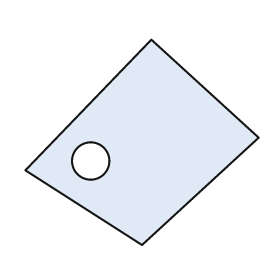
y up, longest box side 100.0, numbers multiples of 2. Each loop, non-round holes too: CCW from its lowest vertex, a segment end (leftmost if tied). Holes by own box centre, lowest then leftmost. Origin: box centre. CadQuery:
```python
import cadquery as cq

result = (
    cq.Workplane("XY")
    .moveTo(0.0, -44.0)
    .lineTo(50.0, 2.0)
    .lineTo(4.0, 44.0)
    .lineTo(-50.0, -12.0)
    .close()
    .moveTo(-22.0, -8.0)
    .circle(8.0)
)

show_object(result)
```